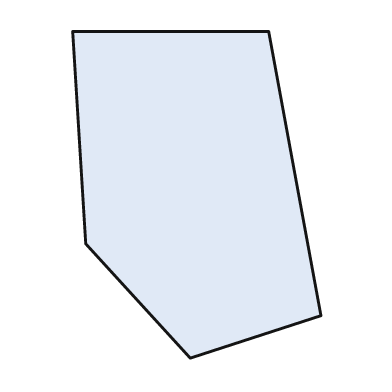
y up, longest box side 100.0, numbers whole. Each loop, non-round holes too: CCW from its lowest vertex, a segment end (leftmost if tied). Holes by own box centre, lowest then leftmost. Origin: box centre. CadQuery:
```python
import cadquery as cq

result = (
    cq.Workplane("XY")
    .moveTo(-2.0, -50.0)
    .lineTo(38.0, -37.0)
    .lineTo(22.0, 50.0)
    .lineTo(-38.0, 50.0)
    .lineTo(-34.0, -15.0)
    .close()
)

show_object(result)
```